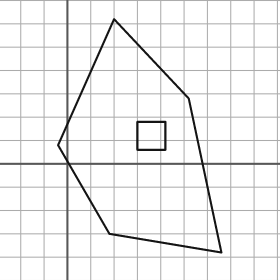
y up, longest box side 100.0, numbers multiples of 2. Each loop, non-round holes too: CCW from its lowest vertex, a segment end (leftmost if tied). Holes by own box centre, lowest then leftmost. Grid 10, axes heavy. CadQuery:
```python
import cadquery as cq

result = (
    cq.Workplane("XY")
    .moveTo(66.0, -38.0)
    .lineTo(52.0, 28.0)
    .lineTo(20.0, 62.0)
    .lineTo(-4.0, 8.0)
    .lineTo(18.0, -30.0)
    .close()
    .moveTo(30.0, 6.0)
    .lineTo(42.0, 6.0)
    .lineTo(42.0, 18.0)
    .lineTo(30.0, 18.0)
    .close()
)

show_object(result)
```